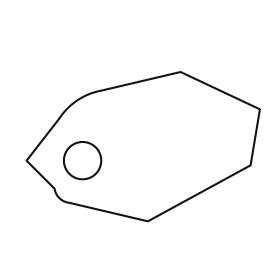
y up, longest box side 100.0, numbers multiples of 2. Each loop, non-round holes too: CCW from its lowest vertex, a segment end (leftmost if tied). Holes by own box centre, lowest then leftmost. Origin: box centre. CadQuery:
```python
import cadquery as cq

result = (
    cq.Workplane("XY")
    .moveTo(2.0, -32.0)
    .lineTo(46.0, -8.0)
    .lineTo(50.0, 16.0)
    .lineTo(16.0, 32.0)
    .lineTo(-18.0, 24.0)
    .threePointArc((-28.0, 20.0), (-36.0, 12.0))
    .lineTo(-50.0, -6.0)
    .lineTo(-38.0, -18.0)
    .threePointArc((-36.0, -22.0), (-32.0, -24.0))
    .close()
    .moveTo(-26.0, -6.0)
    .circle(8.0)
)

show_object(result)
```